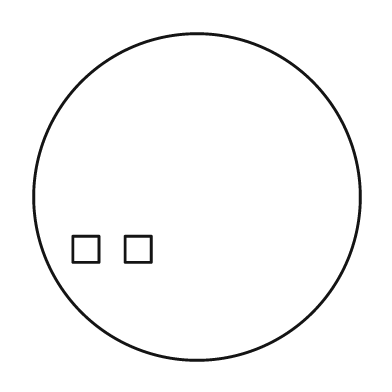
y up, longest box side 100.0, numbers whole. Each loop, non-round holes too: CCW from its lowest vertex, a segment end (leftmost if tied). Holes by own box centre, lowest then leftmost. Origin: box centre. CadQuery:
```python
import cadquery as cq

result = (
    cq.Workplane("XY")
    .moveTo(0.0, 0.0)
    .circle(50.0)
    .moveTo(-38.0, -20.0)
    .lineTo(-30.0, -20.0)
    .lineTo(-30.0, -12.0)
    .lineTo(-38.0, -12.0)
    .close()
    .moveTo(-22.0, -20.0)
    .lineTo(-14.0, -20.0)
    .lineTo(-14.0, -12.0)
    .lineTo(-22.0, -12.0)
    .close()
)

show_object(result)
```